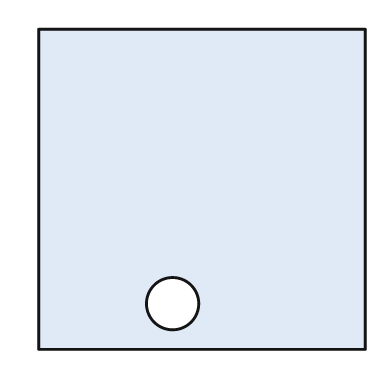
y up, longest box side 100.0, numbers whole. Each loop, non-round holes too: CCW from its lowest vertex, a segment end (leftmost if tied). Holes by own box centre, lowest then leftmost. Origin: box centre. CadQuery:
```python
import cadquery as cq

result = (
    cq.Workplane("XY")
    .moveTo(-50.0, -49.0)
    .lineTo(50.0, -49.0)
    .lineTo(50.0, 49.0)
    .lineTo(-50.0, 49.0)
    .close()
    .moveTo(-9.0, -35.0)
    .circle(8.0)
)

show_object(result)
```